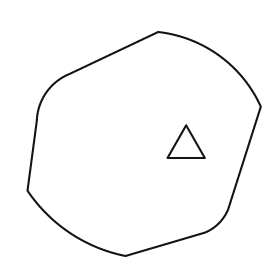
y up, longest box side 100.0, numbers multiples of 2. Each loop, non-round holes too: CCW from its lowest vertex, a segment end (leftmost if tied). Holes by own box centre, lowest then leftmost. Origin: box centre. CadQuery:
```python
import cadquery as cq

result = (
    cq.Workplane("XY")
    .moveTo(-8.0, -48.0)
    .lineTo(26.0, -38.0)
    .threePointArc((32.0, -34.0), (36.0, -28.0))
    .lineTo(50.0, 16.0)
    .threePointArc((32.0, 38.0), (6.0, 48.0))
    .lineTo(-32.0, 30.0)
    .threePointArc((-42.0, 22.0), (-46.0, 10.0))
    .lineTo(-50.0, -20.0)
    .threePointArc((-32.0, -38.0), (-8.0, -48.0))
    .close()
    .moveTo(10.0, -6.0)
    .lineTo(26.0, -6.0)
    .lineTo(18.0, 8.0)
    .close()
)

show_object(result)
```